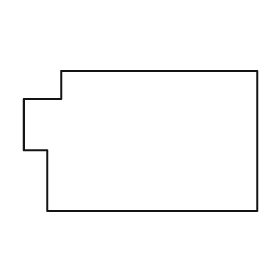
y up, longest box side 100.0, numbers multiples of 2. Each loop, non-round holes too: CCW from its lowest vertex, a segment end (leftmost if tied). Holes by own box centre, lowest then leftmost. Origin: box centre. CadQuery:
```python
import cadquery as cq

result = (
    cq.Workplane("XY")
    .moveTo(-40.0, -30.0)
    .lineTo(50.0, -30.0)
    .lineTo(50.0, 30.0)
    .lineTo(-34.0, 30.0)
    .lineTo(-34.0, 18.0)
    .lineTo(-50.0, 18.0)
    .lineTo(-50.0, -4.0)
    .lineTo(-40.0, -4.0)
    .close()
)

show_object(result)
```